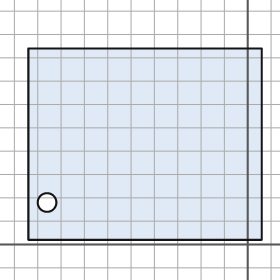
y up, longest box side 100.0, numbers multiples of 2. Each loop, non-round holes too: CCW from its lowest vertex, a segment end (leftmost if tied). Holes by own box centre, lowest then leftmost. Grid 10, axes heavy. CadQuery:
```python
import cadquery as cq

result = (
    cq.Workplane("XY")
    .moveTo(-94.0, 2.0)
    .lineTo(6.0, 2.0)
    .lineTo(6.0, 84.0)
    .lineTo(-94.0, 84.0)
    .close()
    .moveTo(-86.0, 18.0)
    .circle(4.0)
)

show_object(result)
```